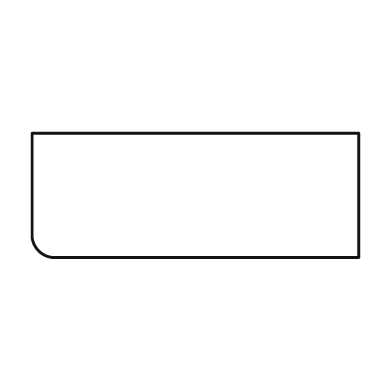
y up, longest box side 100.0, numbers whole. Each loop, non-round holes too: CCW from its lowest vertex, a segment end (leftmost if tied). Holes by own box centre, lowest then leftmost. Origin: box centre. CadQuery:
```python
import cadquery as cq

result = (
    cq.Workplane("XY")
    .moveTo(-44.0, -19.0)
    .lineTo(50.0, -19.0)
    .lineTo(50.0, 19.0)
    .lineTo(-50.0, 19.0)
    .lineTo(-50.0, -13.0)
    .threePointArc((-48.0, -17.0), (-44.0, -19.0))
    .close()
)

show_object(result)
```